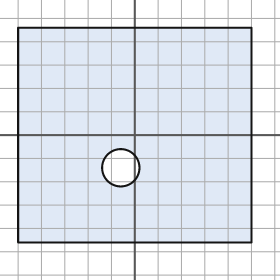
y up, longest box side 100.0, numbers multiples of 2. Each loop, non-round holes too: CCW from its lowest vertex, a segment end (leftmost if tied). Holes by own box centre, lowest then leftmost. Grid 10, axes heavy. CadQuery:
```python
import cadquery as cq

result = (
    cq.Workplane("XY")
    .moveTo(-50.0, -46.0)
    .lineTo(50.0, -46.0)
    .lineTo(50.0, 46.0)
    .lineTo(-50.0, 46.0)
    .close()
    .moveTo(-6.0, -14.0)
    .circle(8.0)
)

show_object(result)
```